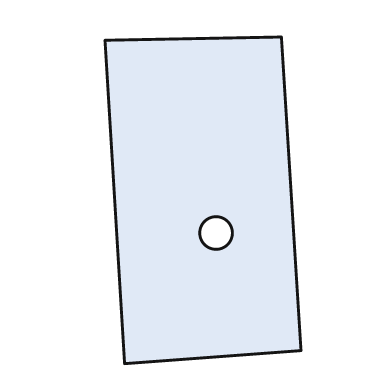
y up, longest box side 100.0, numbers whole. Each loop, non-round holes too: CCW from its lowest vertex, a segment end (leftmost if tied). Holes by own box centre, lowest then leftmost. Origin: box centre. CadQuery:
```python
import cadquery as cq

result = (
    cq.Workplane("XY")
    .moveTo(-24.0, -50.0)
    .lineTo(30.0, -46.0)
    .lineTo(24.0, 50.0)
    .lineTo(-30.0, 49.0)
    .close()
    .moveTo(4.0, -10.0)
    .circle(5.0)
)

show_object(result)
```